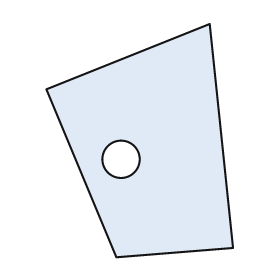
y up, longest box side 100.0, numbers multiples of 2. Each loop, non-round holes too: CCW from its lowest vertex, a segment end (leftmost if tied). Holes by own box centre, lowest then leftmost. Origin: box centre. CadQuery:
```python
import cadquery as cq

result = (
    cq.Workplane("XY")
    .moveTo(-10.0, -50.0)
    .lineTo(40.0, -46.0)
    .lineTo(30.0, 50.0)
    .lineTo(-40.0, 22.0)
    .close()
    .moveTo(-8.0, -8.0)
    .circle(8.0)
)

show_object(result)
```